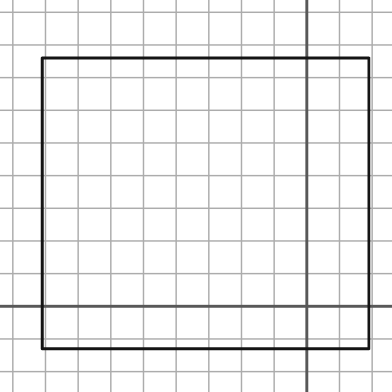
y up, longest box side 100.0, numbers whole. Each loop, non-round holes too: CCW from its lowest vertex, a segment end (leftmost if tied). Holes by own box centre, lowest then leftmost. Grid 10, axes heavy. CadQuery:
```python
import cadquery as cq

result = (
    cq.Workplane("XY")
    .moveTo(-81.0, -13.0)
    .lineTo(19.0, -13.0)
    .lineTo(19.0, 76.0)
    .lineTo(-81.0, 76.0)
    .close()
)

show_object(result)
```